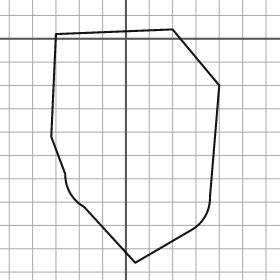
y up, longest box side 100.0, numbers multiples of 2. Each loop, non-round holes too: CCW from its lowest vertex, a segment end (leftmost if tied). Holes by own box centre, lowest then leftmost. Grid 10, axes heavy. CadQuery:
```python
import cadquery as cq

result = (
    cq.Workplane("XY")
    .moveTo(4.0, -96.0)
    .lineTo(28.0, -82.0)
    .threePointArc((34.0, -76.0), (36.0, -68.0))
    .lineTo(40.0, -20.0)
    .lineTo(20.0, 4.0)
    .lineTo(-30.0, 2.0)
    .lineTo(-32.0, -42.0)
    .lineTo(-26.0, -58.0)
    .threePointArc((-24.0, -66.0), (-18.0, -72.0))
    .close()
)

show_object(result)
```